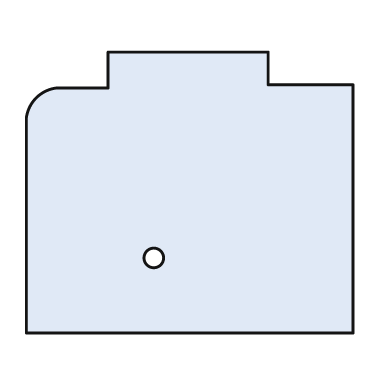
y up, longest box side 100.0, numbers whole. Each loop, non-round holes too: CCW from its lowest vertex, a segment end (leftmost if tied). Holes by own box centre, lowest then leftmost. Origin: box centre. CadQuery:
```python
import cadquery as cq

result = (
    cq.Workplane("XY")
    .moveTo(-50.0, -43.0)
    .lineTo(50.0, -43.0)
    .lineTo(50.0, 33.0)
    .lineTo(24.0, 33.0)
    .lineTo(24.0, 43.0)
    .lineTo(-25.0, 43.0)
    .lineTo(-25.0, 32.0)
    .lineTo(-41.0, 32.0)
    .threePointArc((-47.0, 29.0), (-50.0, 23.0))
    .close()
    .moveTo(-11.0, -20.0)
    .circle(3.0)
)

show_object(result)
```